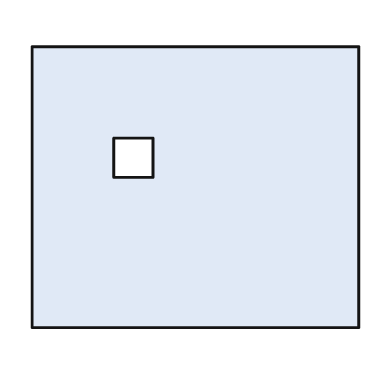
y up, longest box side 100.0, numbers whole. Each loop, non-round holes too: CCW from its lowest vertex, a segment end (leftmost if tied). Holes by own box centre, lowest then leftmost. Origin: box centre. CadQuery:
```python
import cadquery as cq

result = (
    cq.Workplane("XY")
    .moveTo(-50.0, -43.0)
    .lineTo(50.0, -43.0)
    .lineTo(50.0, 43.0)
    .lineTo(-50.0, 43.0)
    .close()
    .moveTo(-25.0, 3.0)
    .lineTo(-13.0, 3.0)
    .lineTo(-13.0, 15.0)
    .lineTo(-25.0, 15.0)
    .close()
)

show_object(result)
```